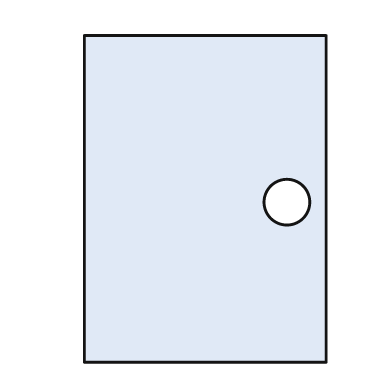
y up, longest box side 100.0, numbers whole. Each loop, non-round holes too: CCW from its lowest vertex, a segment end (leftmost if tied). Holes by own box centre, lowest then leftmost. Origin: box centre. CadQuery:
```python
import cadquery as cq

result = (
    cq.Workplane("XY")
    .moveTo(-37.0, -50.0)
    .lineTo(37.0, -50.0)
    .lineTo(37.0, 50.0)
    .lineTo(-37.0, 50.0)
    .close()
    .moveTo(25.0, -1.0)
    .circle(7.0)
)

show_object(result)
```